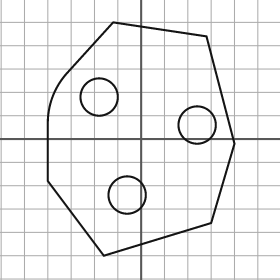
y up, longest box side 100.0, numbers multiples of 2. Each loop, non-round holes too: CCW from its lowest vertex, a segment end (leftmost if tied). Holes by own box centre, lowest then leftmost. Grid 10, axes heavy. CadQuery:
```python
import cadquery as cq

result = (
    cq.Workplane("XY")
    .moveTo(-16.0, -50.0)
    .lineTo(30.0, -36.0)
    .lineTo(40.0, -2.0)
    .lineTo(28.0, 44.0)
    .lineTo(-12.0, 50.0)
    .lineTo(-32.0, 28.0)
    .threePointArc((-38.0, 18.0), (-40.0, 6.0))
    .lineTo(-40.0, -18.0)
    .close()
    .moveTo(-6.0, -24.0)
    .circle(8.0)
    .moveTo(24.0, 6.0)
    .circle(8.0)
    .moveTo(-18.0, 18.0)
    .circle(8.0)
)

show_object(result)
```